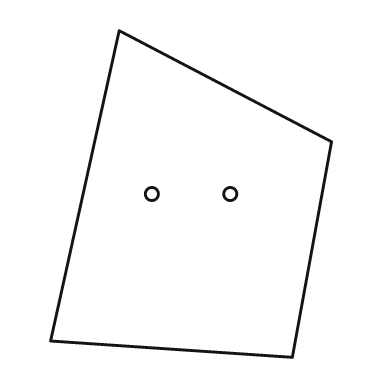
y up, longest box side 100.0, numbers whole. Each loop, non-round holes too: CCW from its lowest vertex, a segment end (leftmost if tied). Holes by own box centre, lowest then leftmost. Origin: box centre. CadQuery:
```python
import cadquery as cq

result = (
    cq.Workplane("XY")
    .moveTo(31.0, -50.0)
    .lineTo(43.0, 16.0)
    .lineTo(-22.0, 50.0)
    .lineTo(-43.0, -45.0)
    .close()
    .moveTo(-12.0, 0.0)
    .circle(2.0)
    .moveTo(12.0, 0.0)
    .circle(2.0)
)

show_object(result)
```